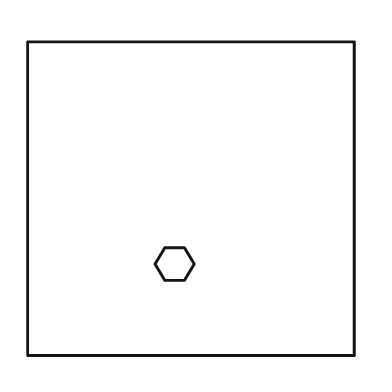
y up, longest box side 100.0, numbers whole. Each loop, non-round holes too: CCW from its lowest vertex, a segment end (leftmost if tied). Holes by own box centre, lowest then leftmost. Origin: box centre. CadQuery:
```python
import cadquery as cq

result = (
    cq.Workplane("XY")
    .moveTo(-50.0, -48.0)
    .lineTo(50.0, -48.0)
    .lineTo(50.0, 48.0)
    .lineTo(-50.0, 48.0)
    .close()
    .moveTo(-8.0, -25.0)
    .lineTo(-2.0, -25.0)
    .lineTo(1.0, -20.0)
    .lineTo(-2.0, -15.0)
    .lineTo(-8.0, -15.0)
    .lineTo(-11.0, -20.0)
    .close()
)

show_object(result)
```